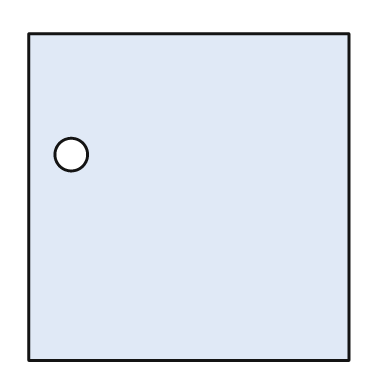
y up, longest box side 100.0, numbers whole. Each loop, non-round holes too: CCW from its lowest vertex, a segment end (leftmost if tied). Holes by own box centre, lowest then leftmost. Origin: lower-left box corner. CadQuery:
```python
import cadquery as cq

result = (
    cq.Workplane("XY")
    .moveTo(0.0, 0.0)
    .lineTo(98.0, 0.0)
    .lineTo(98.0, 100.0)
    .lineTo(0.0, 100.0)
    .close()
    .moveTo(13.0, 63.0)
    .circle(5.0)
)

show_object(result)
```